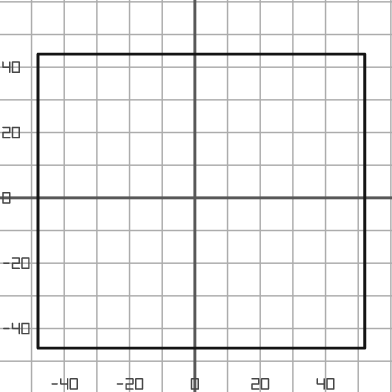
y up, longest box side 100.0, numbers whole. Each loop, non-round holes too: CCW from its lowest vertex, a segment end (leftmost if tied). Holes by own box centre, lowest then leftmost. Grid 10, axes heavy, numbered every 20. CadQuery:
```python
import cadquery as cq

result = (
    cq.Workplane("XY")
    .moveTo(-48.0, -46.0)
    .lineTo(52.0, -46.0)
    .lineTo(52.0, 44.0)
    .lineTo(-48.0, 44.0)
    .close()
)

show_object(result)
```